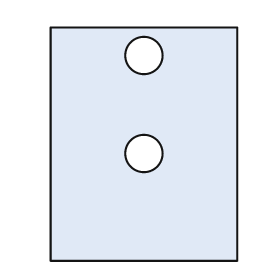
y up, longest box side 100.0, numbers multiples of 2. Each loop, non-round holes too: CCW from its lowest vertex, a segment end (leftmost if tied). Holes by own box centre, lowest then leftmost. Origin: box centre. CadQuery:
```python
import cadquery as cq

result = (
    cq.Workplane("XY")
    .moveTo(-40.0, -50.0)
    .lineTo(40.0, -50.0)
    .lineTo(40.0, 50.0)
    .lineTo(-40.0, 50.0)
    .close()
    .moveTo(0.0, -4.0)
    .circle(8.0)
    .moveTo(0.0, 38.0)
    .circle(8.0)
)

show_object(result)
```